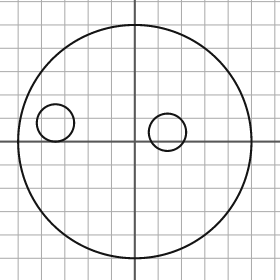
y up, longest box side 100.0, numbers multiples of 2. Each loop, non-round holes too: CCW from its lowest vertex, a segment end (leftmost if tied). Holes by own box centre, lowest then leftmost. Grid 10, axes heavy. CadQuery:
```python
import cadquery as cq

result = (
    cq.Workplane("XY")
    .moveTo(0.0, 0.0)
    .circle(50.0)
    .moveTo(14.0, 4.0)
    .circle(8.0)
    .moveTo(-34.0, 8.0)
    .circle(8.0)
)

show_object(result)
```